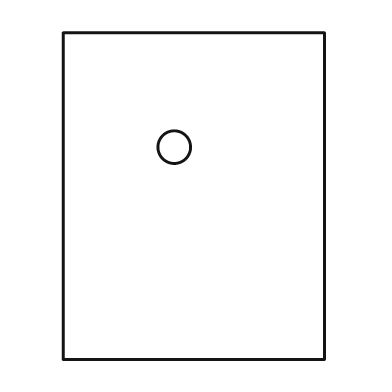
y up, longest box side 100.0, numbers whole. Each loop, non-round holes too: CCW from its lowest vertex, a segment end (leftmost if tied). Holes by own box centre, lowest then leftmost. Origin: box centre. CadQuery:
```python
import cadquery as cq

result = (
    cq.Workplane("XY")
    .moveTo(-40.0, -50.0)
    .lineTo(40.0, -50.0)
    .lineTo(40.0, 50.0)
    .lineTo(-40.0, 50.0)
    .close()
    .moveTo(-6.0, 15.0)
    .circle(5.0)
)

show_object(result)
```